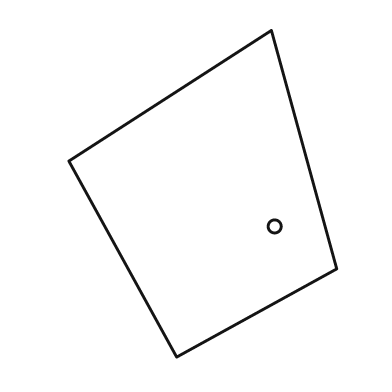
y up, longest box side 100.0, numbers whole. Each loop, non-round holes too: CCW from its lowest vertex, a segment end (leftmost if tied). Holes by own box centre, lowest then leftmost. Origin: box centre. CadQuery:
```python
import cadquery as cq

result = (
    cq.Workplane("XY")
    .moveTo(-8.0, -50.0)
    .lineTo(41.0, -23.0)
    .lineTo(21.0, 50.0)
    .lineTo(-41.0, 10.0)
    .close()
    .moveTo(22.0, -10.0)
    .circle(2.0)
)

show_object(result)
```